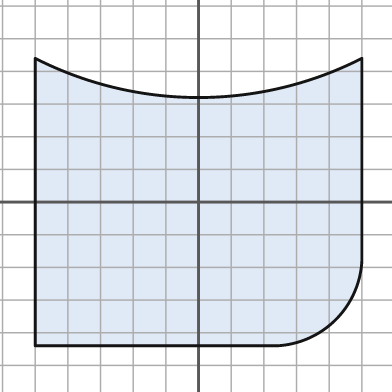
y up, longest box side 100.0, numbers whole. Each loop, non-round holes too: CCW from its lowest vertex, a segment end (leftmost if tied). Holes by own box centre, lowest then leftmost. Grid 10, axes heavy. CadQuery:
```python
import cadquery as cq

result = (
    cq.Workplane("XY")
    .moveTo(-50.0, -44.0)
    .lineTo(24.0, -44.0)
    .threePointArc((42.0, -36.0), (50.0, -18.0))
    .lineTo(50.0, 44.0)
    .threePointArc((0.0, 32.0), (-50.0, 44.0))
    .close()
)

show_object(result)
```